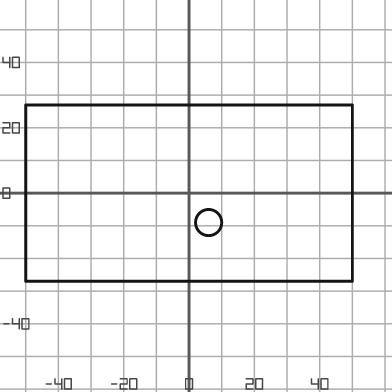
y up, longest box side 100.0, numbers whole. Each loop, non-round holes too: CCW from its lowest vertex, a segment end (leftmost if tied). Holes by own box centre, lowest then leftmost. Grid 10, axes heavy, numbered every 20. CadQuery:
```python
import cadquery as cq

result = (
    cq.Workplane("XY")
    .moveTo(-50.0, -27.0)
    .lineTo(50.0, -27.0)
    .lineTo(50.0, 27.0)
    .lineTo(-50.0, 27.0)
    .close()
    .moveTo(6.0, -9.0)
    .circle(4.0)
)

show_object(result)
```